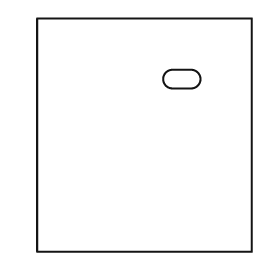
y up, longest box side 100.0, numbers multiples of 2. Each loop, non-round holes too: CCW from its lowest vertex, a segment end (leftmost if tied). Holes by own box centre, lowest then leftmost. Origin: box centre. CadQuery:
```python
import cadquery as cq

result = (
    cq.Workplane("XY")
    .moveTo(-46.0, -50.0)
    .lineTo(46.0, -50.0)
    .lineTo(46.0, 50.0)
    .lineTo(-46.0, 50.0)
    .close()
    .moveTo(12.0, 20.0)
    .lineTo(20.0, 20.0)
    .threePointArc((24.0, 24.0), (20.0, 28.0))
    .lineTo(12.0, 28.0)
    .threePointArc((8.0, 24.0), (12.0, 20.0))
    .close()
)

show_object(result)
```